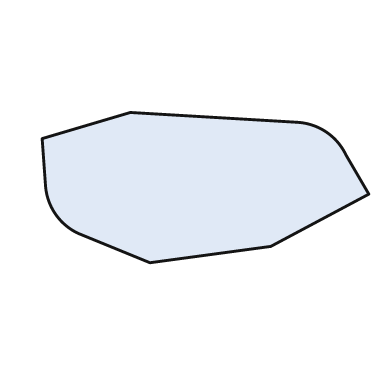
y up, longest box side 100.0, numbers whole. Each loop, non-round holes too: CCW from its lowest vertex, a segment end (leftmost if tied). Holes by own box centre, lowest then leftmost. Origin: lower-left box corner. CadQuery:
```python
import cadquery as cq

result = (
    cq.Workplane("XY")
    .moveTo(33.0, 0.0)
    .lineTo(70.0, 5.0)
    .lineTo(100.0, 21.0)
    .lineTo(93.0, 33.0)
    .threePointArc((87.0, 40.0), (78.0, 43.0))
    .lineTo(27.0, 46.0)
    .lineTo(0.0, 38.0)
    .lineTo(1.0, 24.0)
    .threePointArc((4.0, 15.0), (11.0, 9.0))
    .close()
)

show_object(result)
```